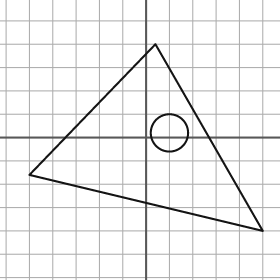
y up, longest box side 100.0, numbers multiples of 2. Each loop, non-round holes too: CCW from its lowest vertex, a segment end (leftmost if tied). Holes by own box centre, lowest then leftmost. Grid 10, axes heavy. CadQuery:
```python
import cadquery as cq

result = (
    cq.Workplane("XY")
    .moveTo(50.0, -40.0)
    .lineTo(4.0, 40.0)
    .lineTo(-50.0, -16.0)
    .close()
    .moveTo(10.0, 2.0)
    .circle(8.0)
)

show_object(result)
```